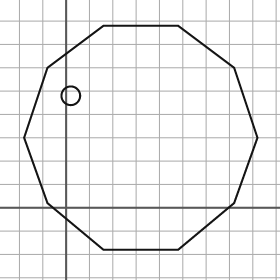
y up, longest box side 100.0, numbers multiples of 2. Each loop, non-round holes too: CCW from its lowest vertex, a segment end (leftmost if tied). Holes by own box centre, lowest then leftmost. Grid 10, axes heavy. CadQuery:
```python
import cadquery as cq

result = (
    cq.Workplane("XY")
    .moveTo(16.0, -18.0)
    .lineTo(48.0, -18.0)
    .lineTo(72.0, 2.0)
    .lineTo(82.0, 30.0)
    .lineTo(72.0, 60.0)
    .lineTo(48.0, 78.0)
    .lineTo(16.0, 78.0)
    .lineTo(-8.0, 60.0)
    .lineTo(-18.0, 30.0)
    .lineTo(-8.0, 2.0)
    .close()
    .moveTo(2.0, 48.0)
    .circle(4.0)
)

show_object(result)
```